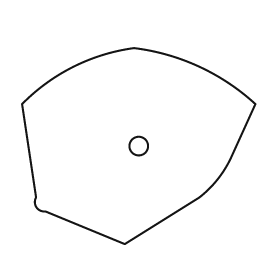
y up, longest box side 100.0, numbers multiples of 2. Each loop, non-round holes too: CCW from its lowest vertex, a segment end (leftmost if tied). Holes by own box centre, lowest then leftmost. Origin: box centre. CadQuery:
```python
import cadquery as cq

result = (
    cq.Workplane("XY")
    .moveTo(-6.0, -42.0)
    .lineTo(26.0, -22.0)
    .threePointArc((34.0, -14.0), (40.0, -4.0))
    .lineTo(50.0, 18.0)
    .threePointArc((26.0, 34.0), (-2.0, 42.0))
    .threePointArc((-28.0, 34.0), (-50.0, 18.0))
    .lineTo(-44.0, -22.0)
    .threePointArc((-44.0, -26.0), (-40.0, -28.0))
    .close()
    .moveTo(0.0, 0.0)
    .circle(4.0)
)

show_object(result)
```